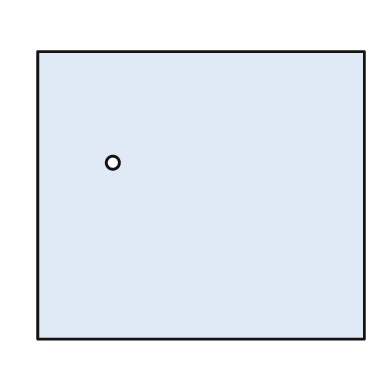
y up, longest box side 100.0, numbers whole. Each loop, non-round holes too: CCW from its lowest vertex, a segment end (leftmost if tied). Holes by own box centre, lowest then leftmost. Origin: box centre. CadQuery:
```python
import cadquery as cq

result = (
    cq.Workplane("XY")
    .moveTo(-50.0, -44.0)
    .lineTo(50.0, -44.0)
    .lineTo(50.0, 44.0)
    .lineTo(-50.0, 44.0)
    .close()
    .moveTo(-27.0, 10.0)
    .circle(2.0)
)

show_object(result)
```